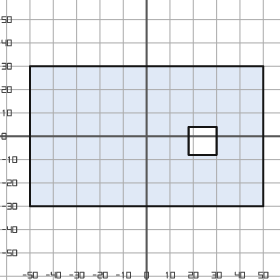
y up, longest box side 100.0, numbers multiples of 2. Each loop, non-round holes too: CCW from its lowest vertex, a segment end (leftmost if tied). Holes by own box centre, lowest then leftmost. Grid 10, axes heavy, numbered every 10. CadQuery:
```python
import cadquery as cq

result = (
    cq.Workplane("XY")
    .moveTo(-50.0, -30.0)
    .lineTo(50.0, -30.0)
    .lineTo(50.0, 30.0)
    .lineTo(-50.0, 30.0)
    .close()
    .moveTo(18.0, -8.0)
    .lineTo(30.0, -8.0)
    .lineTo(30.0, 4.0)
    .lineTo(18.0, 4.0)
    .close()
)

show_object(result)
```